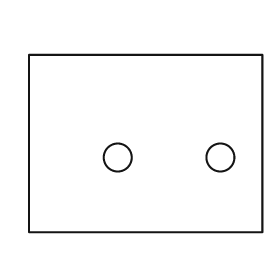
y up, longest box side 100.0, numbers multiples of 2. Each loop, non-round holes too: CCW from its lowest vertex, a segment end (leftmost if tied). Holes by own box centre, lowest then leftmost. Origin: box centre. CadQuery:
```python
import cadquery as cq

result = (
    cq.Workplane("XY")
    .moveTo(-50.0, -38.0)
    .lineTo(50.0, -38.0)
    .lineTo(50.0, 38.0)
    .lineTo(-50.0, 38.0)
    .close()
    .moveTo(-12.0, -6.0)
    .circle(6.0)
    .moveTo(32.0, -6.0)
    .circle(6.0)
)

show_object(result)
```